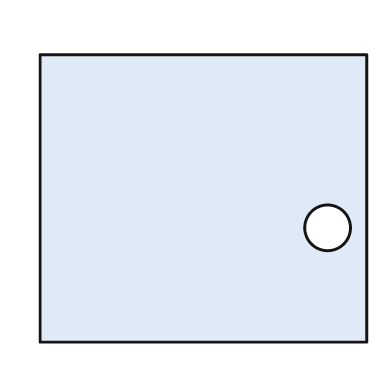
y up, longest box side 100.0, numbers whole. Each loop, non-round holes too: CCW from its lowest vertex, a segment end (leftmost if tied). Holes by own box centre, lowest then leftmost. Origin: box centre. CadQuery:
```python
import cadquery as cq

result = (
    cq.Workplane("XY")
    .moveTo(-50.0, -44.0)
    .lineTo(50.0, -44.0)
    .lineTo(50.0, 44.0)
    .lineTo(-50.0, 44.0)
    .close()
    .moveTo(38.0, -9.0)
    .circle(7.0)
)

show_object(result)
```